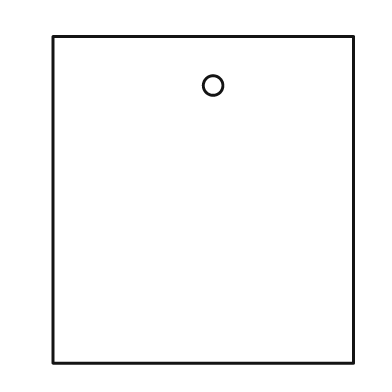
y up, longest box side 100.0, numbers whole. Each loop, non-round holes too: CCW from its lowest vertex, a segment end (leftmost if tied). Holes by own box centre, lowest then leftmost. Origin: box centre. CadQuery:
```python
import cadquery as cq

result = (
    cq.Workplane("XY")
    .moveTo(-46.0, -50.0)
    .lineTo(46.0, -50.0)
    .lineTo(46.0, 50.0)
    .lineTo(-46.0, 50.0)
    .close()
    .moveTo(3.0, 35.0)
    .circle(3.0)
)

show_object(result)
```